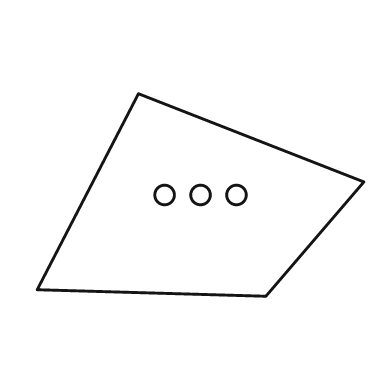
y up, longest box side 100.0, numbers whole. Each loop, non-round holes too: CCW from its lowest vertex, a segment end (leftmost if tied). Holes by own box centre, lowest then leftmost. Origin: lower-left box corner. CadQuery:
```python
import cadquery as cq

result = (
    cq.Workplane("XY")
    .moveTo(70.0, 0.0)
    .lineTo(100.0, 35.0)
    .lineTo(31.0, 62.0)
    .lineTo(0.0, 2.0)
    .close()
    .moveTo(39.0, 31.0)
    .circle(3.0)
    .moveTo(50.0, 31.0)
    .circle(3.0)
    .moveTo(61.0, 31.0)
    .circle(3.0)
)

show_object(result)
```